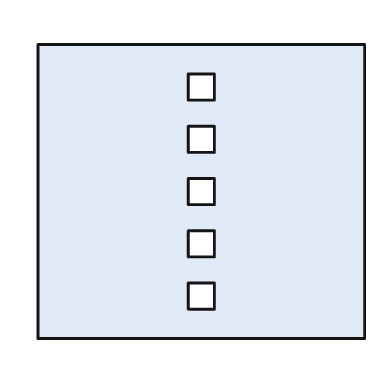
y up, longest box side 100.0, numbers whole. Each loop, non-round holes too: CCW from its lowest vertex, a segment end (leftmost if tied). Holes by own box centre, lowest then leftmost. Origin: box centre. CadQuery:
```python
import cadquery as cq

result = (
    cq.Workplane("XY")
    .moveTo(-50.0, -45.0)
    .lineTo(50.0, -45.0)
    .lineTo(50.0, 45.0)
    .lineTo(-50.0, 45.0)
    .close()
    .moveTo(-4.0, -36.0)
    .lineTo(4.0, -36.0)
    .lineTo(4.0, -28.0)
    .lineTo(-4.0, -28.0)
    .close()
    .moveTo(-4.0, -20.0)
    .lineTo(4.0, -20.0)
    .lineTo(4.0, -12.0)
    .lineTo(-4.0, -12.0)
    .close()
    .moveTo(-4.0, -4.0)
    .lineTo(4.0, -4.0)
    .lineTo(4.0, 4.0)
    .lineTo(-4.0, 4.0)
    .close()
    .moveTo(-4.0, 12.0)
    .lineTo(4.0, 12.0)
    .lineTo(4.0, 20.0)
    .lineTo(-4.0, 20.0)
    .close()
    .moveTo(-4.0, 28.0)
    .lineTo(4.0, 28.0)
    .lineTo(4.0, 36.0)
    .lineTo(-4.0, 36.0)
    .close()
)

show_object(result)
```